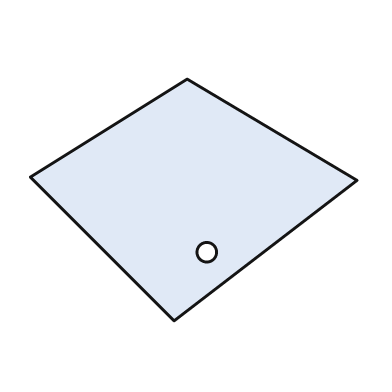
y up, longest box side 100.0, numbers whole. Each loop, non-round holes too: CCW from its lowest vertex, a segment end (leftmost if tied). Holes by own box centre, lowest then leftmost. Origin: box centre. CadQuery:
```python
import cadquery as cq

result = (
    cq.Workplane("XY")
    .moveTo(-6.0, -37.0)
    .lineTo(50.0, 6.0)
    .lineTo(-2.0, 37.0)
    .lineTo(-50.0, 7.0)
    .close()
    .moveTo(4.0, -16.0)
    .circle(3.0)
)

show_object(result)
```